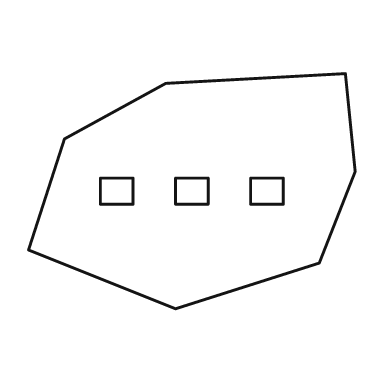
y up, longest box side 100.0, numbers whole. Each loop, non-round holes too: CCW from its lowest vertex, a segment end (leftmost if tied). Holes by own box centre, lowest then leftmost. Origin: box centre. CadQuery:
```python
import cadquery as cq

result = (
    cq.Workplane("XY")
    .moveTo(-5.0, -36.0)
    .lineTo(39.0, -22.0)
    .lineTo(50.0, 6.0)
    .lineTo(47.0, 36.0)
    .lineTo(-8.0, 33.0)
    .lineTo(-39.0, 16.0)
    .lineTo(-50.0, -18.0)
    .close()
    .moveTo(-28.0, -4.0)
    .lineTo(-18.0, -4.0)
    .lineTo(-18.0, 4.0)
    .lineTo(-28.0, 4.0)
    .close()
    .moveTo(-5.0, -4.0)
    .lineTo(5.0, -4.0)
    .lineTo(5.0, 4.0)
    .lineTo(-5.0, 4.0)
    .close()
    .moveTo(18.0, -4.0)
    .lineTo(28.0, -4.0)
    .lineTo(28.0, 4.0)
    .lineTo(18.0, 4.0)
    .close()
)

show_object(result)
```